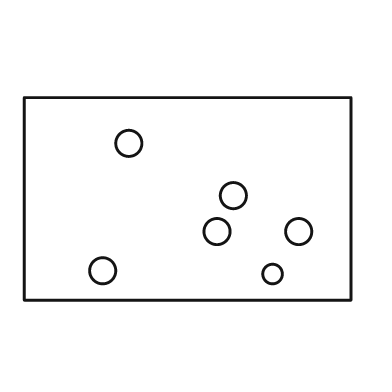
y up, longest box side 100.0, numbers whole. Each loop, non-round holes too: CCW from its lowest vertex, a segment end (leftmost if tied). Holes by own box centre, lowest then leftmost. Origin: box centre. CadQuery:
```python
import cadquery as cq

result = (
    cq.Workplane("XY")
    .moveTo(-50.0, -31.0)
    .lineTo(50.0, -31.0)
    .lineTo(50.0, 31.0)
    .lineTo(-50.0, 31.0)
    .close()
    .moveTo(26.0, -23.0)
    .circle(3.0)
    .moveTo(-26.0, -22.0)
    .circle(4.0)
    .moveTo(9.0, -10.0)
    .circle(4.0)
    .moveTo(34.0, -10.0)
    .circle(4.0)
    .moveTo(14.0, 1.0)
    .circle(4.0)
    .moveTo(-18.0, 17.0)
    .circle(4.0)
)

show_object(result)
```